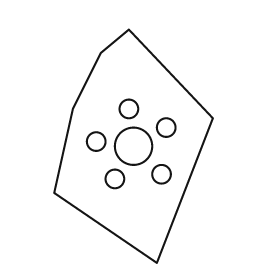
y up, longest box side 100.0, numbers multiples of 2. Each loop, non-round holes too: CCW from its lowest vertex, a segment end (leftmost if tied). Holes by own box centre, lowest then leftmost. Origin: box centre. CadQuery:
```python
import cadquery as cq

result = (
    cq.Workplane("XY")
    .moveTo(10.0, -50.0)
    .lineTo(34.0, 12.0)
    .lineTo(-2.0, 50.0)
    .lineTo(-14.0, 40.0)
    .lineTo(-26.0, 16.0)
    .lineTo(-34.0, -20.0)
    .close()
    .moveTo(-8.0, -14.0)
    .circle(4.0)
    .moveTo(12.0, -12.0)
    .circle(4.0)
    .moveTo(0.0, 0.0)
    .circle(8.0)
    .moveTo(-16.0, 2.0)
    .circle(4.0)
    .moveTo(14.0, 8.0)
    .circle(4.0)
    .moveTo(-2.0, 16.0)
    .circle(4.0)
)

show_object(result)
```